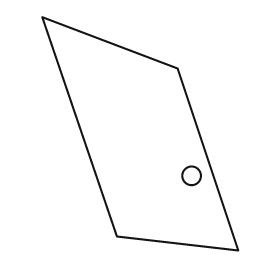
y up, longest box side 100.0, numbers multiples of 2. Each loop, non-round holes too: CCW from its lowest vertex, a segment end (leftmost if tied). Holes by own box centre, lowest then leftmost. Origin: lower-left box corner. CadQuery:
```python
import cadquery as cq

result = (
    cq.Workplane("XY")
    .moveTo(84.0, 0.0)
    .lineTo(58.0, 78.0)
    .lineTo(0.0, 100.0)
    .lineTo(32.0, 6.0)
    .close()
    .moveTo(64.0, 32.0)
    .circle(4.0)
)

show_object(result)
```